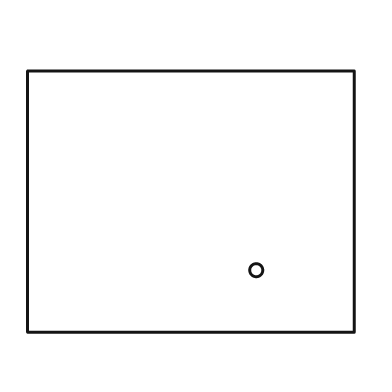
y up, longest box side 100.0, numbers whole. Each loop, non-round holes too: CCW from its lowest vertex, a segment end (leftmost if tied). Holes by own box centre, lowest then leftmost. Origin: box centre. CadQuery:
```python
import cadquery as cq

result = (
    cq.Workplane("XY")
    .moveTo(-50.0, -40.0)
    .lineTo(50.0, -40.0)
    .lineTo(50.0, 40.0)
    .lineTo(-50.0, 40.0)
    .close()
    .moveTo(20.0, -21.0)
    .circle(2.0)
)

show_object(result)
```